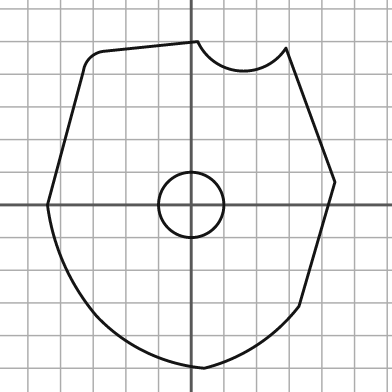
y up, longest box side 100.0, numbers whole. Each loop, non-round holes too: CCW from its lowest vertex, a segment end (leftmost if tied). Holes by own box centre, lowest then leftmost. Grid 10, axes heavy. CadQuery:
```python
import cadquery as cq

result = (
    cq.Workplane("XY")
    .moveTo(4.0, -50.0)
    .threePointArc((20.0, -43.0), (33.0, -31.0))
    .lineTo(44.0, 7.0)
    .lineTo(29.0, 48.0)
    .threePointArc((15.0, 41.0), (2.0, 50.0))
    .lineTo(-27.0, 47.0)
    .threePointArc((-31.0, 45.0), (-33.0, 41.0))
    .lineTo(-44.0, 0.0)
    .threePointArc((-39.0, -18.0), (-29.0, -34.0))
    .threePointArc((-14.0, -45.0), (4.0, -50.0))
    .close()
    .moveTo(0.0, 0.0)
    .circle(10.0)
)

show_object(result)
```